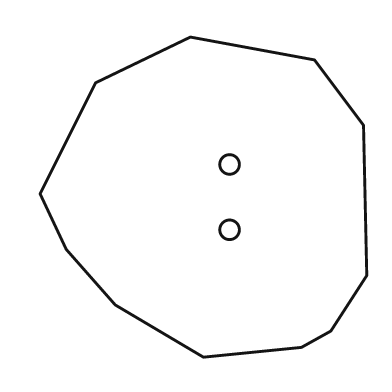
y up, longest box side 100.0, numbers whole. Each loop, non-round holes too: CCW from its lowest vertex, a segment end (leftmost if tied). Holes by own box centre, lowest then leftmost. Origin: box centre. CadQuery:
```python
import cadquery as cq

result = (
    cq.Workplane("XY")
    .moveTo(0.0, -49.0)
    .lineTo(30.0, -46.0)
    .lineTo(39.0, -41.0)
    .lineTo(50.0, -24.0)
    .lineTo(49.0, 22.0)
    .lineTo(34.0, 42.0)
    .lineTo(-4.0, 49.0)
    .lineTo(-33.0, 35.0)
    .lineTo(-50.0, 1.0)
    .lineTo(-42.0, -16.0)
    .lineTo(-27.0, -33.0)
    .close()
    .moveTo(8.0, -10.0)
    .circle(3.0)
    .moveTo(8.0, 10.0)
    .circle(3.0)
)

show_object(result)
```